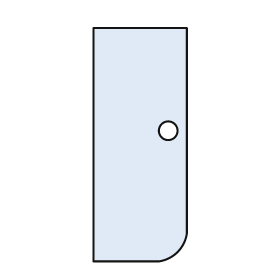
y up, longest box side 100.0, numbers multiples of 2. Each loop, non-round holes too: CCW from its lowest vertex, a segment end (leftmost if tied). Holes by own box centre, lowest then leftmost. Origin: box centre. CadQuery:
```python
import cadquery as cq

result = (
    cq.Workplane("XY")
    .moveTo(-20.0, -50.0)
    .lineTo(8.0, -50.0)
    .threePointArc((16.0, -46.0), (20.0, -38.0))
    .lineTo(20.0, 50.0)
    .lineTo(-20.0, 50.0)
    .close()
    .moveTo(12.0, 6.0)
    .circle(4.0)
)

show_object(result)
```